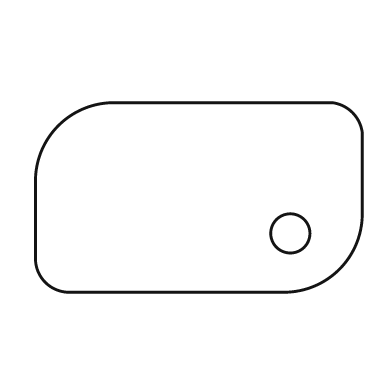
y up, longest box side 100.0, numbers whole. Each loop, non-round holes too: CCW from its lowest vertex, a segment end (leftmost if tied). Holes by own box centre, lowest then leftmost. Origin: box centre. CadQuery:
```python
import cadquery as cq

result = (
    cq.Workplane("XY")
    .moveTo(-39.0, -29.0)
    .lineTo(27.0, -29.0)
    .threePointArc((43.0, -22.0), (50.0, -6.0))
    .lineTo(50.0, 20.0)
    .threePointArc((47.0, 26.0), (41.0, 29.0))
    .lineTo(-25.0, 29.0)
    .threePointArc((-43.0, 22.0), (-50.0, 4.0))
    .lineTo(-50.0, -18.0)
    .threePointArc((-47.0, -26.0), (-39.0, -29.0))
    .close()
    .moveTo(28.0, -11.0)
    .circle(6.0)
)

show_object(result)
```